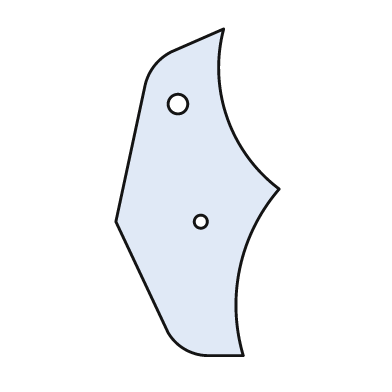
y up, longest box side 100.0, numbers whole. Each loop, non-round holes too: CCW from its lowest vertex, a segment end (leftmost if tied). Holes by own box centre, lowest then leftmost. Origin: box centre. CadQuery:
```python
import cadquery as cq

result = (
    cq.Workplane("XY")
    .moveTo(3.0, -50.0)
    .lineTo(14.0, -50.0)
    .threePointArc((13.0, -23.0), (25.0, 1.0))
    .threePointArc((9.0, 23.0), (8.0, 50.0))
    .lineTo(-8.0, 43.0)
    .threePointArc((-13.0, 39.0), (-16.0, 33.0))
    .lineTo(-25.0, -9.0)
    .lineTo(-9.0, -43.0)
    .threePointArc((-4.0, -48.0), (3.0, -50.0))
    .close()
    .moveTo(1.0, -9.0)
    .circle(2.0)
    .moveTo(-6.0, 27.0)
    .circle(3.0)
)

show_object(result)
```